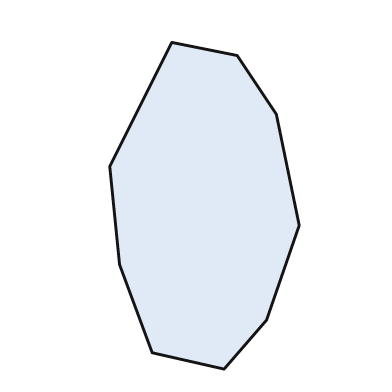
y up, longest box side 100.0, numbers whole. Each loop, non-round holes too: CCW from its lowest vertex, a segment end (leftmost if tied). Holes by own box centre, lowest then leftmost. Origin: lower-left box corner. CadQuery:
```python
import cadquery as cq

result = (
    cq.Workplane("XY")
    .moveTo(35.0, 0.0)
    .lineTo(48.0, 15.0)
    .lineTo(58.0, 44.0)
    .lineTo(51.0, 78.0)
    .lineTo(39.0, 96.0)
    .lineTo(19.0, 100.0)
    .lineTo(0.0, 62.0)
    .lineTo(3.0, 32.0)
    .lineTo(13.0, 5.0)
    .close()
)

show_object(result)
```